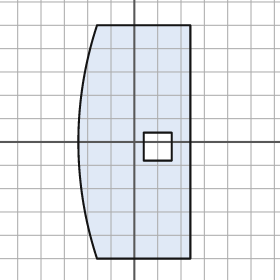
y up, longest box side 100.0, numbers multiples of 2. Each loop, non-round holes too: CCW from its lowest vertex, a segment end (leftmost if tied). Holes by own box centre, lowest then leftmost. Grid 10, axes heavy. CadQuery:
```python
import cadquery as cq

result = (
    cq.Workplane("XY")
    .moveTo(-16.0, -50.0)
    .lineTo(24.0, -50.0)
    .lineTo(24.0, 50.0)
    .lineTo(-16.0, 50.0)
    .threePointArc((-24.0, 0.0), (-16.0, -50.0))
    .close()
    .moveTo(4.0, -8.0)
    .lineTo(16.0, -8.0)
    .lineTo(16.0, 4.0)
    .lineTo(4.0, 4.0)
    .close()
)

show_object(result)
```